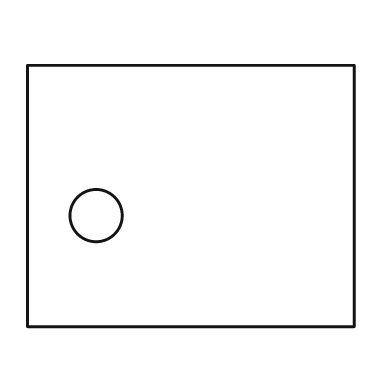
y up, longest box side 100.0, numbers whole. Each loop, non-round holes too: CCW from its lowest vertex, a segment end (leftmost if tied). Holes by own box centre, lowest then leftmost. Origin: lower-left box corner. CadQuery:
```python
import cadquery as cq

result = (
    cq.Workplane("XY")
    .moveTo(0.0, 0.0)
    .lineTo(100.0, 0.0)
    .lineTo(100.0, 80.0)
    .lineTo(0.0, 80.0)
    .close()
    .moveTo(21.0, 34.0)
    .circle(8.0)
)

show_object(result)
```